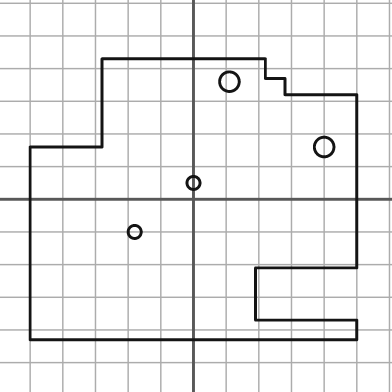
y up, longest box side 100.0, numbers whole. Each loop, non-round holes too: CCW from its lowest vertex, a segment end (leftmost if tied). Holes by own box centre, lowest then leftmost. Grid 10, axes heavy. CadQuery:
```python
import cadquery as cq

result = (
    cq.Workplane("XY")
    .moveTo(-50.0, -43.0)
    .lineTo(50.0, -43.0)
    .lineTo(50.0, -37.0)
    .lineTo(19.0, -37.0)
    .lineTo(19.0, -21.0)
    .lineTo(50.0, -21.0)
    .lineTo(50.0, 32.0)
    .lineTo(28.0, 32.0)
    .lineTo(28.0, 37.0)
    .lineTo(22.0, 37.0)
    .lineTo(22.0, 43.0)
    .lineTo(-28.0, 43.0)
    .lineTo(-28.0, 16.0)
    .lineTo(-50.0, 16.0)
    .close()
    .moveTo(-18.0, -10.0)
    .circle(2.0)
    .moveTo(0.0, 5.0)
    .circle(2.0)
    .moveTo(40.0, 16.0)
    .circle(3.0)
    .moveTo(11.0, 36.0)
    .circle(3.0)
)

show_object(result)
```